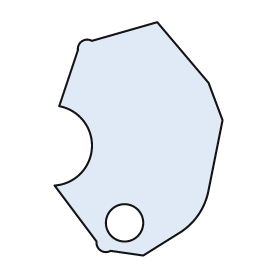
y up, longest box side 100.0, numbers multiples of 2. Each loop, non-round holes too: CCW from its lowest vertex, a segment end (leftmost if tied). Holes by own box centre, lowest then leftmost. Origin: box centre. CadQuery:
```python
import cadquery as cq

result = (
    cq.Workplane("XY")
    .moveTo(2.0, -50.0)
    .lineTo(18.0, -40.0)
    .threePointArc((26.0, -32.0), (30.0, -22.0))
    .lineTo(36.0, 8.0)
    .lineTo(30.0, 24.0)
    .lineTo(8.0, 50.0)
    .lineTo(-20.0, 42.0)
    .threePointArc((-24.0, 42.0), (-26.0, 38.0))
    .lineTo(-34.0, 14.0)
    .threePointArc((-20.0, -4.0), (-36.0, -20.0))
    .lineTo(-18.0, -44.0)
    .threePointArc((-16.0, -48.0), (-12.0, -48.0))
    .close()
    .moveTo(-6.0, -36.0)
    .circle(8.0)
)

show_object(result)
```